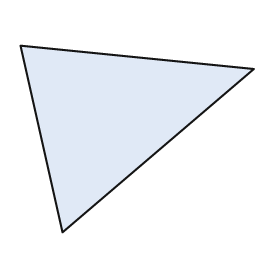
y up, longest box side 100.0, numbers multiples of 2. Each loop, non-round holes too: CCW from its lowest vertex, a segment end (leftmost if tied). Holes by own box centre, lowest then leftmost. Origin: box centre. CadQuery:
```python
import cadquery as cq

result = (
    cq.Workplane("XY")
    .moveTo(-32.0, -40.0)
    .lineTo(50.0, 30.0)
    .lineTo(-50.0, 40.0)
    .close()
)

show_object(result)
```